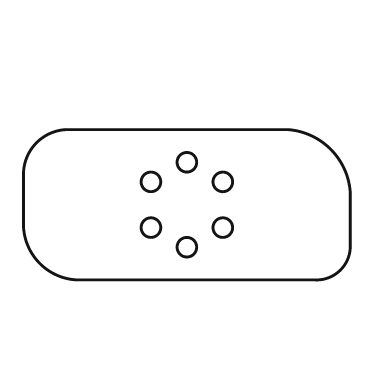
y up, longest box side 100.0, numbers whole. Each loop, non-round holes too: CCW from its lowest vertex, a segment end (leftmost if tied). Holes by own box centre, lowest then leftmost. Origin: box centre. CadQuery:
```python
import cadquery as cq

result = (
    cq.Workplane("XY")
    .moveTo(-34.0, -23.0)
    .lineTo(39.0, -23.0)
    .threePointArc((47.0, -20.0), (50.0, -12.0))
    .lineTo(50.0, 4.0)
    .threePointArc((44.0, 17.0), (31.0, 23.0))
    .lineTo(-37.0, 23.0)
    .threePointArc((-46.0, 19.0), (-50.0, 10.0))
    .lineTo(-50.0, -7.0)
    .threePointArc((-45.0, -18.0), (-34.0, -23.0))
    .close()
    .moveTo(0.0, -13.0)
    .circle(3.0)
    .moveTo(-11.0, -7.0)
    .circle(3.0)
    .moveTo(11.0, -7.0)
    .circle(3.0)
    .moveTo(-11.0, 7.0)
    .circle(3.0)
    .moveTo(11.0, 7.0)
    .circle(3.0)
    .moveTo(0.0, 13.0)
    .circle(3.0)
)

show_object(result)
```